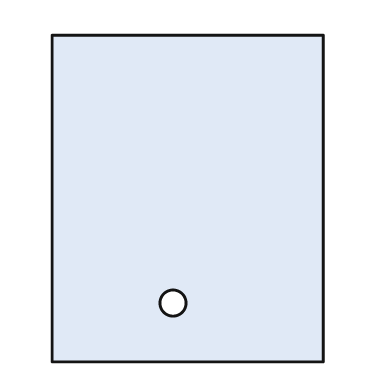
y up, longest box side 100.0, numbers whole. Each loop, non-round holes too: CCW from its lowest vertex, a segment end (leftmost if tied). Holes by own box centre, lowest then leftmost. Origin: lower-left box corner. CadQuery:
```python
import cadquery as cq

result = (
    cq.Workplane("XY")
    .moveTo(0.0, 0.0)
    .lineTo(83.0, 0.0)
    .lineTo(83.0, 100.0)
    .lineTo(0.0, 100.0)
    .close()
    .moveTo(37.0, 18.0)
    .circle(4.0)
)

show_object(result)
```